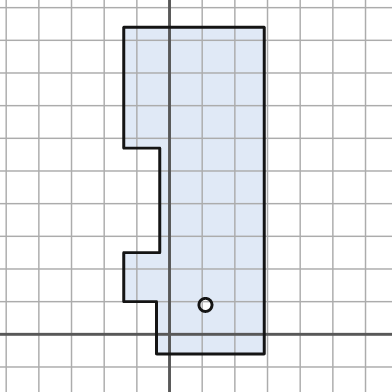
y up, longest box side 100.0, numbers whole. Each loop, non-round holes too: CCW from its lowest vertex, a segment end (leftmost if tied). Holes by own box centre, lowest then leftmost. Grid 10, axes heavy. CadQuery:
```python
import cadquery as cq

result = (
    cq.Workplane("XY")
    .moveTo(-4.0, -6.0)
    .lineTo(29.0, -6.0)
    .lineTo(29.0, 94.0)
    .lineTo(-14.0, 94.0)
    .lineTo(-14.0, 57.0)
    .lineTo(-3.0, 57.0)
    .lineTo(-3.0, 25.0)
    .lineTo(-14.0, 25.0)
    .lineTo(-14.0, 10.0)
    .lineTo(-4.0, 10.0)
    .close()
    .moveTo(11.0, 9.0)
    .circle(2.0)
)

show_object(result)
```